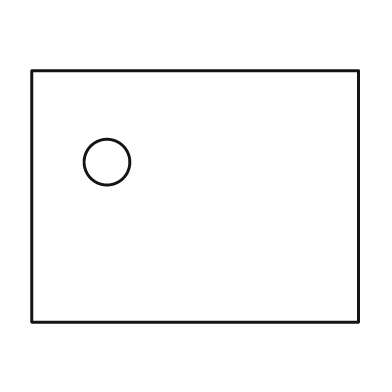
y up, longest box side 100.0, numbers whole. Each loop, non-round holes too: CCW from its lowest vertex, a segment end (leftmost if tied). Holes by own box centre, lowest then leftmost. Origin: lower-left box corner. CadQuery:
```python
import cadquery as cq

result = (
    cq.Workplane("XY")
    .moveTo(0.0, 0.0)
    .lineTo(100.0, 0.0)
    .lineTo(100.0, 77.0)
    .lineTo(0.0, 77.0)
    .close()
    .moveTo(23.0, 49.0)
    .circle(7.0)
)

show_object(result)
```